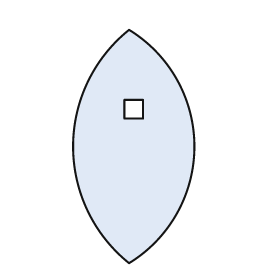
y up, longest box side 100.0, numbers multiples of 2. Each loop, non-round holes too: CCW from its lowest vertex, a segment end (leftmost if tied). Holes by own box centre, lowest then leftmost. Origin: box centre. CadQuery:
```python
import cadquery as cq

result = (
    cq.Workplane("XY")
    .moveTo(-2.0, -50.0)
    .threePointArc((26.0, 0.0), (-2.0, 50.0))
    .threePointArc((-26.0, 0.0), (-2.0, -50.0))
    .close()
    .moveTo(-4.0, 12.0)
    .lineTo(4.0, 12.0)
    .lineTo(4.0, 20.0)
    .lineTo(-4.0, 20.0)
    .close()
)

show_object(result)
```